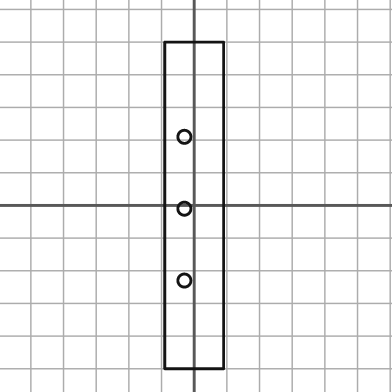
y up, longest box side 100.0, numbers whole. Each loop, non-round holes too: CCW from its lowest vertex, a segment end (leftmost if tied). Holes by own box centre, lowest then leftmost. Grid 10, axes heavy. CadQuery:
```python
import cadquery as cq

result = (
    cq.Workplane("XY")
    .moveTo(-9.0, -50.0)
    .lineTo(9.0, -50.0)
    .lineTo(9.0, 50.0)
    .lineTo(-9.0, 50.0)
    .close()
    .moveTo(-3.0, -23.0)
    .circle(2.0)
    .moveTo(-3.0, -1.0)
    .circle(2.0)
    .moveTo(-3.0, 21.0)
    .circle(2.0)
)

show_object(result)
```